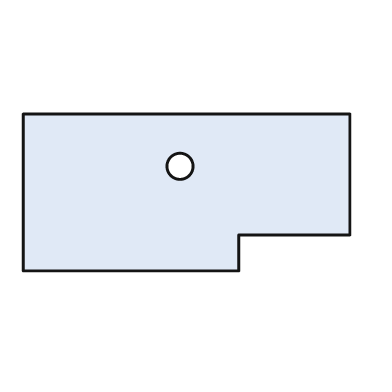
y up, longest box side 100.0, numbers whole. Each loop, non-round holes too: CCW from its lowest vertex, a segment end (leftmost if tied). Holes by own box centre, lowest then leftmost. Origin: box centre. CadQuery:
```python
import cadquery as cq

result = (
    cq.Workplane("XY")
    .moveTo(-50.0, -24.0)
    .lineTo(16.0, -24.0)
    .lineTo(16.0, -13.0)
    .lineTo(50.0, -13.0)
    .lineTo(50.0, 24.0)
    .lineTo(-50.0, 24.0)
    .close()
    .moveTo(-2.0, 8.0)
    .circle(4.0)
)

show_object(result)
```